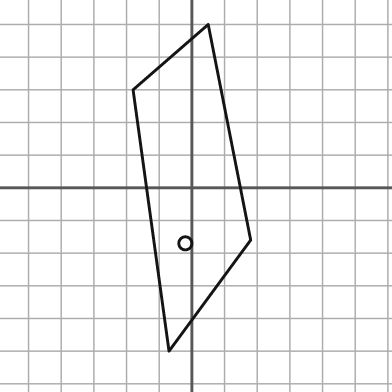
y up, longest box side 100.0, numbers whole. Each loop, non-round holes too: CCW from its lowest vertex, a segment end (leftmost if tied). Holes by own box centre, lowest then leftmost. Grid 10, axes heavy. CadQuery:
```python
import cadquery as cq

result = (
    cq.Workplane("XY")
    .moveTo(-7.0, -50.0)
    .lineTo(18.0, -16.0)
    .lineTo(5.0, 50.0)
    .lineTo(-18.0, 30.0)
    .close()
    .moveTo(-2.0, -17.0)
    .circle(2.0)
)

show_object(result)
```